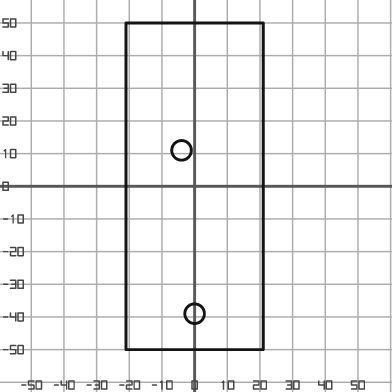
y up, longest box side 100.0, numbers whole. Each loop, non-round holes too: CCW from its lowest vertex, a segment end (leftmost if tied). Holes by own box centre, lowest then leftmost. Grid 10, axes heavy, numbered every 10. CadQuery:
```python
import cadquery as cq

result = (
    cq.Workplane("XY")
    .moveTo(-21.0, -50.0)
    .lineTo(21.0, -50.0)
    .lineTo(21.0, 50.0)
    .lineTo(-21.0, 50.0)
    .close()
    .moveTo(0.0, -39.0)
    .circle(3.0)
    .moveTo(-4.0, 11.0)
    .circle(3.0)
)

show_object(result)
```